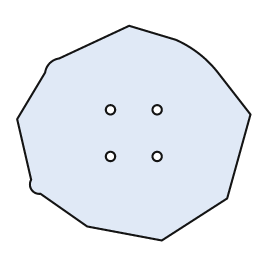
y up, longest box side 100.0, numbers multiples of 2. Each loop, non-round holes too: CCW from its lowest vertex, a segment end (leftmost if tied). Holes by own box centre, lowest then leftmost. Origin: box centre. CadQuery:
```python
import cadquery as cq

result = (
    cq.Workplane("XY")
    .moveTo(12.0, -46.0)
    .lineTo(40.0, -28.0)
    .lineTo(50.0, 8.0)
    .lineTo(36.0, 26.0)
    .threePointArc((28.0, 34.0), (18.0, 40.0))
    .lineTo(-2.0, 46.0)
    .lineTo(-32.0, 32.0)
    .threePointArc((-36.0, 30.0), (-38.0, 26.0))
    .lineTo(-50.0, 6.0)
    .lineTo(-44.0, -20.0)
    .threePointArc((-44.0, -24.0), (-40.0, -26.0))
    .lineTo(-20.0, -40.0)
    .close()
    .moveTo(-10.0, -10.0)
    .circle(2.0)
    .moveTo(10.0, -10.0)
    .circle(2.0)
    .moveTo(-10.0, 10.0)
    .circle(2.0)
    .moveTo(10.0, 10.0)
    .circle(2.0)
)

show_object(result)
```